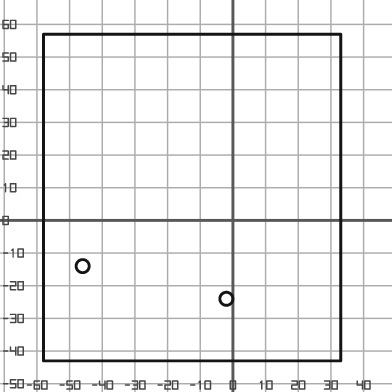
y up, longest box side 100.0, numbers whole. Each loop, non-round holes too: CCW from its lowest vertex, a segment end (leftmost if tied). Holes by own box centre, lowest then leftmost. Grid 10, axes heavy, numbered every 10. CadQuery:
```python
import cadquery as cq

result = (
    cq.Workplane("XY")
    .moveTo(-58.0, -43.0)
    .lineTo(33.0, -43.0)
    .lineTo(33.0, 57.0)
    .lineTo(-58.0, 57.0)
    .close()
    .moveTo(-2.0, -24.0)
    .circle(2.0)
    .moveTo(-46.0, -14.0)
    .circle(2.0)
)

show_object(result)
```